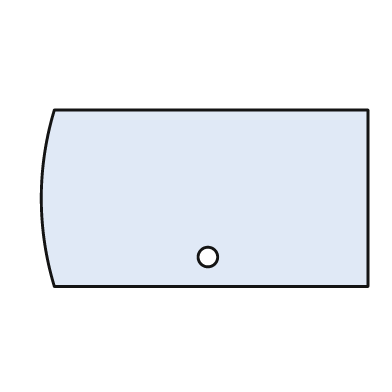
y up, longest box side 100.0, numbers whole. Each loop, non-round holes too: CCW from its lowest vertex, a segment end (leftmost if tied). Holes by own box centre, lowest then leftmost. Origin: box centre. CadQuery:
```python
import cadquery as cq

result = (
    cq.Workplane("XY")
    .moveTo(-46.0, -27.0)
    .lineTo(50.0, -27.0)
    .lineTo(50.0, 27.0)
    .lineTo(-46.0, 27.0)
    .threePointArc((-50.0, 0.0), (-46.0, -27.0))
    .close()
    .moveTo(1.0, -18.0)
    .circle(3.0)
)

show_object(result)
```